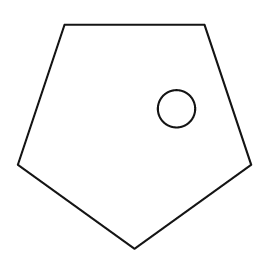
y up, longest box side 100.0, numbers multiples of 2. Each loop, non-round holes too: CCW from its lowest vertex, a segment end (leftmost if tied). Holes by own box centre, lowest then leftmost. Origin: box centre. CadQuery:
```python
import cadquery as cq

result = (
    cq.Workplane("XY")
    .moveTo(0.0, -48.0)
    .lineTo(50.0, -12.0)
    .lineTo(30.0, 48.0)
    .lineTo(-30.0, 48.0)
    .lineTo(-50.0, -12.0)
    .close()
    .moveTo(18.0, 12.0)
    .circle(8.0)
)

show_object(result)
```